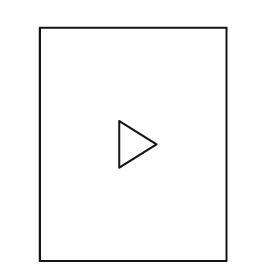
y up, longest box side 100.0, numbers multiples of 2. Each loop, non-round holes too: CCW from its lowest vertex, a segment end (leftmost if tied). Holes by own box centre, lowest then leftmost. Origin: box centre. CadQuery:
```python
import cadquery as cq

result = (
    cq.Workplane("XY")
    .moveTo(-40.0, -50.0)
    .lineTo(40.0, -50.0)
    .lineTo(40.0, 50.0)
    .lineTo(-40.0, 50.0)
    .close()
    .moveTo(-6.0, -10.0)
    .lineTo(10.0, 0.0)
    .lineTo(-6.0, 10.0)
    .close()
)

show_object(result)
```